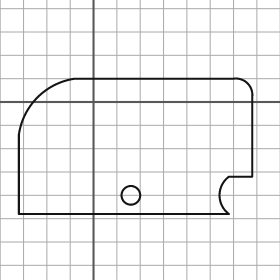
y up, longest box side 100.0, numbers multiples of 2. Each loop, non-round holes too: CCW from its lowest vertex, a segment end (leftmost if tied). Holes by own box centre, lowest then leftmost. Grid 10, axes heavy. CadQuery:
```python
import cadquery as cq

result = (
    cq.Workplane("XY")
    .moveTo(-32.0, -48.0)
    .lineTo(58.0, -48.0)
    .threePointArc((54.0, -40.0), (58.0, -32.0))
    .lineTo(68.0, -32.0)
    .lineTo(68.0, 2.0)
    .threePointArc((66.0, 8.0), (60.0, 10.0))
    .lineTo(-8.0, 10.0)
    .threePointArc((-24.0, 2.0), (-32.0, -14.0))
    .close()
    .moveTo(16.0, -40.0)
    .circle(4.0)
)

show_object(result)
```